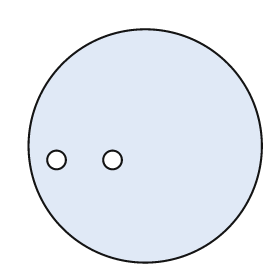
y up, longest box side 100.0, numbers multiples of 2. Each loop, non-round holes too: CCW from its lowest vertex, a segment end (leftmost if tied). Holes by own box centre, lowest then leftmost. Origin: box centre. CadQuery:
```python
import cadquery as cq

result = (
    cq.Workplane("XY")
    .moveTo(0.0, 0.0)
    .circle(50.0)
    .moveTo(-38.0, -6.0)
    .circle(4.0)
    .moveTo(-14.0, -6.0)
    .circle(4.0)
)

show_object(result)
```